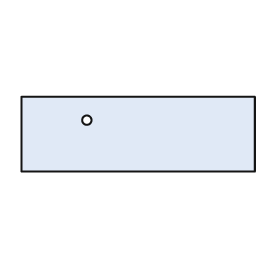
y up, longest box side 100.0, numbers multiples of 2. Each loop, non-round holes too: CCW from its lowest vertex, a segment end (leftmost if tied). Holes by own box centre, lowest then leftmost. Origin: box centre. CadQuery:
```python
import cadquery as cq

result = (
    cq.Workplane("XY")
    .moveTo(-50.0, -16.0)
    .lineTo(50.0, -16.0)
    .lineTo(50.0, 16.0)
    .lineTo(-50.0, 16.0)
    .close()
    .moveTo(-22.0, 6.0)
    .circle(2.0)
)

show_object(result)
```